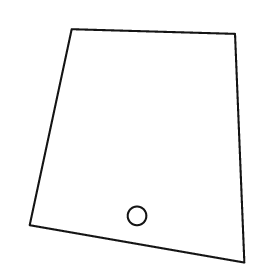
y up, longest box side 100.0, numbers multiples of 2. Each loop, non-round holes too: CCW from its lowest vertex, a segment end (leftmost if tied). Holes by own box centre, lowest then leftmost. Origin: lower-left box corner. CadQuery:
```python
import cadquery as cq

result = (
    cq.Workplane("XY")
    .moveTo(92.0, 0.0)
    .lineTo(88.0, 98.0)
    .lineTo(18.0, 100.0)
    .lineTo(0.0, 16.0)
    .close()
    .moveTo(46.0, 20.0)
    .circle(4.0)
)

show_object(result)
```